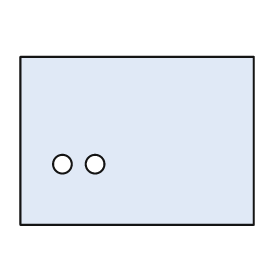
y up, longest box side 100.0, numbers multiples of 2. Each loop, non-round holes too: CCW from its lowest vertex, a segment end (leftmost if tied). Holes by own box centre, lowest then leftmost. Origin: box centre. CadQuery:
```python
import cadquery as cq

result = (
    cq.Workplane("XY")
    .moveTo(-50.0, -36.0)
    .lineTo(50.0, -36.0)
    .lineTo(50.0, 36.0)
    .lineTo(-50.0, 36.0)
    .close()
    .moveTo(-32.0, -10.0)
    .circle(4.0)
    .moveTo(-18.0, -10.0)
    .circle(4.0)
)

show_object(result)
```